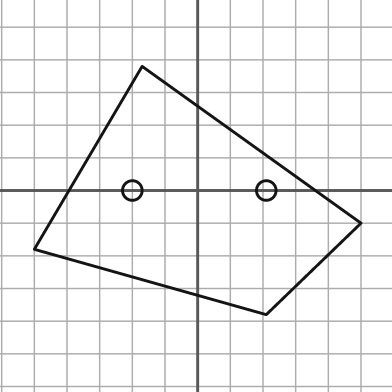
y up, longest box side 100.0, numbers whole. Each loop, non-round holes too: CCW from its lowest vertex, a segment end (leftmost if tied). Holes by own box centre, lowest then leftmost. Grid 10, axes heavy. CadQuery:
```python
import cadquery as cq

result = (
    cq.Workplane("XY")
    .moveTo(21.0, -38.0)
    .lineTo(50.0, -10.0)
    .lineTo(-17.0, 38.0)
    .lineTo(-50.0, -18.0)
    .close()
    .moveTo(-20.0, 0.0)
    .circle(3.0)
    .moveTo(21.0, 0.0)
    .circle(3.0)
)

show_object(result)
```